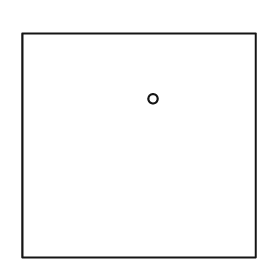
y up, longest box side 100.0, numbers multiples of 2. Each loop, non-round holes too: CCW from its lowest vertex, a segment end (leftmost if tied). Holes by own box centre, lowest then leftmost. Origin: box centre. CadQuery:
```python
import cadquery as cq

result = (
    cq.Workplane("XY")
    .moveTo(-50.0, -48.0)
    .lineTo(50.0, -48.0)
    .lineTo(50.0, 48.0)
    .lineTo(-50.0, 48.0)
    .close()
    .moveTo(6.0, 20.0)
    .circle(2.0)
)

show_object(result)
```